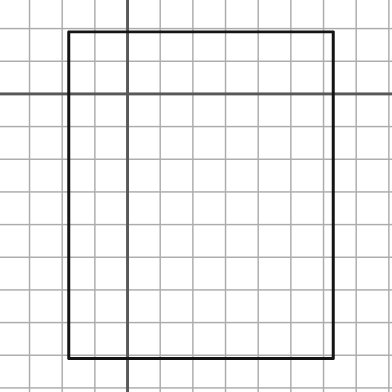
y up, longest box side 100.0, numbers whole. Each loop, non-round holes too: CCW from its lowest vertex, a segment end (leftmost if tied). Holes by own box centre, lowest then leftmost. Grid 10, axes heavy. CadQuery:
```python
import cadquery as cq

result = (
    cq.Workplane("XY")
    .moveTo(-18.0, -81.0)
    .lineTo(63.0, -81.0)
    .lineTo(63.0, 19.0)
    .lineTo(-18.0, 19.0)
    .close()
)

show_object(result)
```